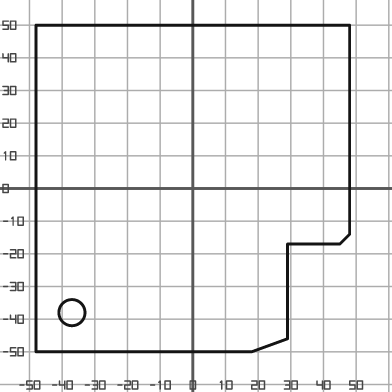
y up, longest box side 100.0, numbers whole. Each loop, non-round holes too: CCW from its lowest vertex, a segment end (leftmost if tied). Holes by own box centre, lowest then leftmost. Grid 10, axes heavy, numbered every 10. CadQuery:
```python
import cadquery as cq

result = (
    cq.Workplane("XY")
    .moveTo(-48.0, -50.0)
    .lineTo(18.0, -50.0)
    .lineTo(29.0, -46.0)
    .lineTo(29.0, -17.0)
    .lineTo(45.0, -17.0)
    .lineTo(48.0, -14.0)
    .lineTo(48.0, 50.0)
    .lineTo(-48.0, 50.0)
    .close()
    .moveTo(-37.0, -38.0)
    .circle(4.0)
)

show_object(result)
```